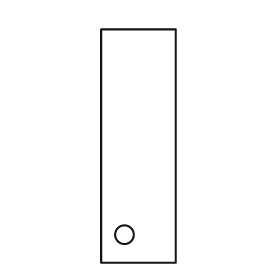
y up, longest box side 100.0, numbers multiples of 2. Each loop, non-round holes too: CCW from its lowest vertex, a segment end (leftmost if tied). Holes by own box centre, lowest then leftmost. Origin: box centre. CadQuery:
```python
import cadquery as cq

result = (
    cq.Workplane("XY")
    .moveTo(-16.0, -50.0)
    .lineTo(16.0, -50.0)
    .lineTo(16.0, 50.0)
    .lineTo(-16.0, 50.0)
    .close()
    .moveTo(-6.0, -38.0)
    .circle(4.0)
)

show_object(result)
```